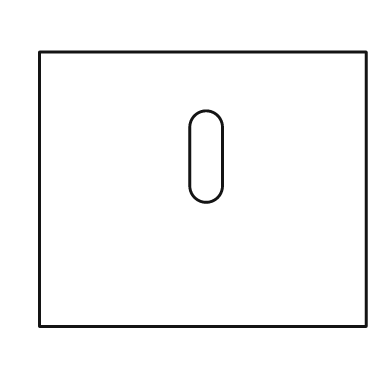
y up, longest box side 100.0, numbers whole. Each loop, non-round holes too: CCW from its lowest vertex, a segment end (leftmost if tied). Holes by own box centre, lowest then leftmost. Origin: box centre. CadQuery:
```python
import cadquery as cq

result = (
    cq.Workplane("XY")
    .moveTo(-50.0, -42.0)
    .lineTo(50.0, -42.0)
    .lineTo(50.0, 42.0)
    .lineTo(-50.0, 42.0)
    .close()
    .moveTo(-4.0, 1.0)
    .threePointArc((1.0, -4.0), (6.0, 1.0))
    .lineTo(6.0, 19.0)
    .threePointArc((1.0, 24.0), (-4.0, 19.0))
    .close()
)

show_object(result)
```